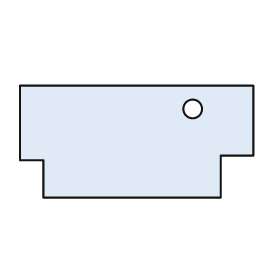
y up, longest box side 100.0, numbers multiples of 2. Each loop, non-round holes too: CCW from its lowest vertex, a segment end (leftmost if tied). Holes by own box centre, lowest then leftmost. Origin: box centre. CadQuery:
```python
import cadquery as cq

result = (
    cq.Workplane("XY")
    .moveTo(-40.0, -24.0)
    .lineTo(36.0, -24.0)
    .lineTo(36.0, -6.0)
    .lineTo(50.0, -6.0)
    .lineTo(50.0, 24.0)
    .lineTo(-50.0, 24.0)
    .lineTo(-50.0, -8.0)
    .lineTo(-40.0, -8.0)
    .close()
    .moveTo(24.0, 14.0)
    .circle(4.0)
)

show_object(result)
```